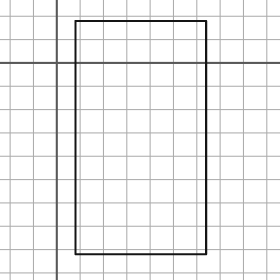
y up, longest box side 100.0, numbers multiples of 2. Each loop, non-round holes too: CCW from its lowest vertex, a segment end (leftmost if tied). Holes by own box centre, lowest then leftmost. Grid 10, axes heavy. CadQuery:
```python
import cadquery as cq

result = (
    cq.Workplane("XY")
    .moveTo(8.0, -82.0)
    .lineTo(64.0, -82.0)
    .lineTo(64.0, 18.0)
    .lineTo(8.0, 18.0)
    .close()
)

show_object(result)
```